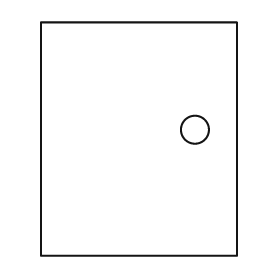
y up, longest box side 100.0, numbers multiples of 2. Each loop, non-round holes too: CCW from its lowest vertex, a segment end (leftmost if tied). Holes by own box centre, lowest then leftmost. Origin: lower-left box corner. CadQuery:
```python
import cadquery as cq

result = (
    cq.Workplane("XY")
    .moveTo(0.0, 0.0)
    .lineTo(84.0, 0.0)
    .lineTo(84.0, 100.0)
    .lineTo(0.0, 100.0)
    .close()
    .moveTo(66.0, 54.0)
    .circle(6.0)
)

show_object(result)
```